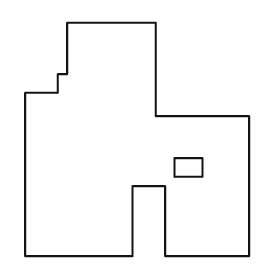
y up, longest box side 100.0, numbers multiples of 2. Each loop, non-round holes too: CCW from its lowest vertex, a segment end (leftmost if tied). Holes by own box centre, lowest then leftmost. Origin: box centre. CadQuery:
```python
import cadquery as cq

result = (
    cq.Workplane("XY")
    .moveTo(-48.0, -50.0)
    .lineTo(-2.0, -50.0)
    .lineTo(-2.0, -20.0)
    .lineTo(12.0, -20.0)
    .lineTo(12.0, -50.0)
    .lineTo(48.0, -50.0)
    .lineTo(48.0, 10.0)
    .lineTo(8.0, 10.0)
    .lineTo(8.0, 50.0)
    .lineTo(-30.0, 50.0)
    .lineTo(-30.0, 28.0)
    .lineTo(-34.0, 28.0)
    .lineTo(-34.0, 20.0)
    .lineTo(-48.0, 20.0)
    .close()
    .moveTo(16.0, -16.0)
    .lineTo(28.0, -16.0)
    .lineTo(28.0, -8.0)
    .lineTo(16.0, -8.0)
    .close()
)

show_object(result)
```